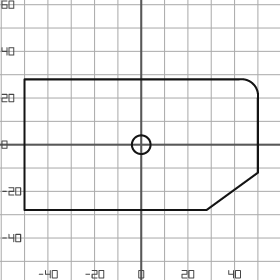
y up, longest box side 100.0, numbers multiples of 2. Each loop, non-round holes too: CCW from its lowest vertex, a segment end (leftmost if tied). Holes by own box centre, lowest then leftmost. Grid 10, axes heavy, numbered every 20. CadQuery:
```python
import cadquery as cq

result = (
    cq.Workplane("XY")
    .moveTo(-50.0, -28.0)
    .lineTo(28.0, -28.0)
    .lineTo(50.0, -12.0)
    .lineTo(50.0, 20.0)
    .threePointArc((48.0, 26.0), (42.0, 28.0))
    .lineTo(-50.0, 28.0)
    .close()
    .moveTo(0.0, 0.0)
    .circle(4.0)
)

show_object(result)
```